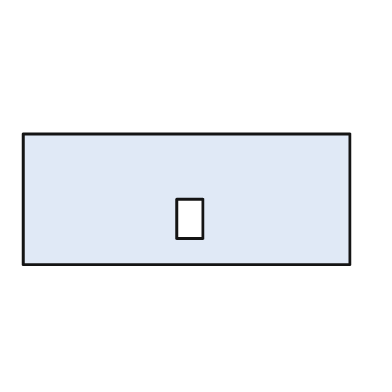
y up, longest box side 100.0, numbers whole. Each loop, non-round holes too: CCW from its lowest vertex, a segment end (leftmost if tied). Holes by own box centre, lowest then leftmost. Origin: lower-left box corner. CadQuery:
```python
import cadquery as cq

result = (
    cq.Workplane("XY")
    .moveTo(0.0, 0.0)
    .lineTo(100.0, 0.0)
    .lineTo(100.0, 40.0)
    .lineTo(0.0, 40.0)
    .close()
    .moveTo(47.0, 8.0)
    .lineTo(55.0, 8.0)
    .lineTo(55.0, 20.0)
    .lineTo(47.0, 20.0)
    .close()
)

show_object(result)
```